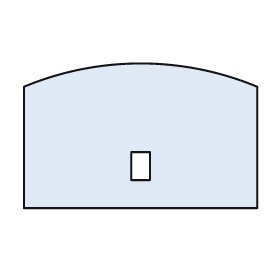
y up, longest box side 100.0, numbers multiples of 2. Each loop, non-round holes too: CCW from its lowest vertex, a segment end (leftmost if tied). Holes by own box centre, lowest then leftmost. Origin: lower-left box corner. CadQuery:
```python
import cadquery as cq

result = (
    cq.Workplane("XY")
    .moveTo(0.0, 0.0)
    .lineTo(100.0, 0.0)
    .lineTo(100.0, 52.0)
    .threePointArc((50.0, 62.0), (0.0, 52.0))
    .close()
    .moveTo(46.0, 12.0)
    .lineTo(54.0, 12.0)
    .lineTo(54.0, 24.0)
    .lineTo(46.0, 24.0)
    .close()
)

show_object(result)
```